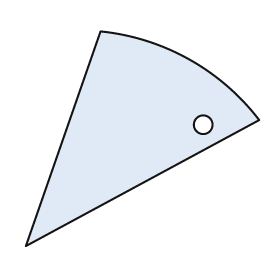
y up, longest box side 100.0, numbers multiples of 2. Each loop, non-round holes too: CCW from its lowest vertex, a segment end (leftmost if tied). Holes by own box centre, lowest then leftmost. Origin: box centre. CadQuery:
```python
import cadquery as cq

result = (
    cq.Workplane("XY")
    .moveTo(-50.0, -46.0)
    .lineTo(50.0, 8.0)
    .threePointArc((20.0, 34.0), (-18.0, 46.0))
    .close()
    .moveTo(26.0, 6.0)
    .circle(4.0)
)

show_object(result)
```